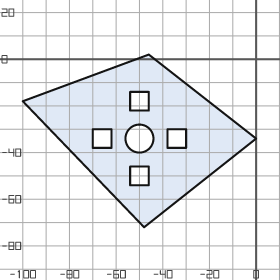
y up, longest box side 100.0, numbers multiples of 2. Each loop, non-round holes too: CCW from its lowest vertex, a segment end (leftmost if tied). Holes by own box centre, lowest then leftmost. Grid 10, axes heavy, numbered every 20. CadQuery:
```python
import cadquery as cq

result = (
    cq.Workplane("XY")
    .moveTo(-48.0, -72.0)
    .lineTo(0.0, -34.0)
    .lineTo(-46.0, 2.0)
    .lineTo(-100.0, -18.0)
    .close()
    .moveTo(-54.0, -54.0)
    .lineTo(-46.0, -54.0)
    .lineTo(-46.0, -46.0)
    .lineTo(-54.0, -46.0)
    .close()
    .moveTo(-70.0, -38.0)
    .lineTo(-62.0, -38.0)
    .lineTo(-62.0, -30.0)
    .lineTo(-70.0, -30.0)
    .close()
    .moveTo(-50.0, -34.0)
    .circle(6.0)
    .moveTo(-38.0, -38.0)
    .lineTo(-30.0, -38.0)
    .lineTo(-30.0, -30.0)
    .lineTo(-38.0, -30.0)
    .close()
    .moveTo(-54.0, -22.0)
    .lineTo(-46.0, -22.0)
    .lineTo(-46.0, -14.0)
    .lineTo(-54.0, -14.0)
    .close()
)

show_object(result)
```